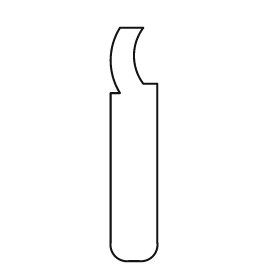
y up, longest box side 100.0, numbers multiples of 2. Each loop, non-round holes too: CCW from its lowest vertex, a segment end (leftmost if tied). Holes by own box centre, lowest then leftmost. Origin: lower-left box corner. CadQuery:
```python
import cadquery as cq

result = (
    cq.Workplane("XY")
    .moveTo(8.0, 0.0)
    .lineTo(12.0, 0.0)
    .threePointArc((18.0, 2.0), (20.0, 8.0))
    .lineTo(20.0, 76.0)
    .lineTo(14.0, 76.0)
    .threePointArc((10.0, 88.0), (14.0, 100.0))
    .lineTo(4.0, 100.0)
    .threePointArc((0.0, 86.0), (4.0, 72.0))
    .lineTo(0.0, 72.0)
    .lineTo(0.0, 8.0)
    .threePointArc((2.0, 2.0), (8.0, 0.0))
    .close()
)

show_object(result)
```